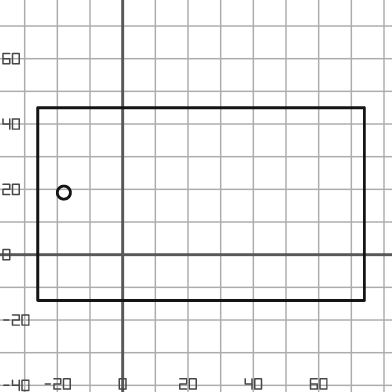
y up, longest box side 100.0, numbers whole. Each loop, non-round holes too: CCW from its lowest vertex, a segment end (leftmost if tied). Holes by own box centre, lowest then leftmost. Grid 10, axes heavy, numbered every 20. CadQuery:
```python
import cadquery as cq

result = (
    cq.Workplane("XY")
    .moveTo(-26.0, -14.0)
    .lineTo(74.0, -14.0)
    .lineTo(74.0, 45.0)
    .lineTo(-26.0, 45.0)
    .close()
    .moveTo(-18.0, 19.0)
    .circle(2.0)
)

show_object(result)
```